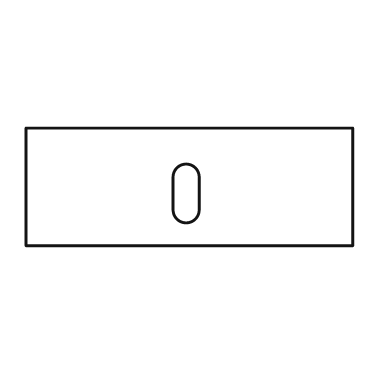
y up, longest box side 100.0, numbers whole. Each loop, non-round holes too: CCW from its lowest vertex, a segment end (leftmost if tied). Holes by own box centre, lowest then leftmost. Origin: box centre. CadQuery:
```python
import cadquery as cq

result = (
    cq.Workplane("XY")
    .moveTo(-50.0, -18.0)
    .lineTo(50.0, -18.0)
    .lineTo(50.0, 18.0)
    .lineTo(-50.0, 18.0)
    .close()
    .moveTo(-5.0, -7.0)
    .threePointArc((-1.0, -11.0), (3.0, -7.0))
    .lineTo(3.0, 3.0)
    .threePointArc((-1.0, 7.0), (-5.0, 3.0))
    .close()
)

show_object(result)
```